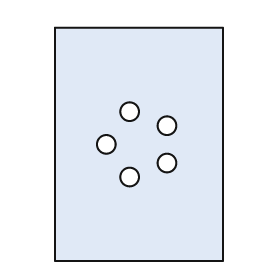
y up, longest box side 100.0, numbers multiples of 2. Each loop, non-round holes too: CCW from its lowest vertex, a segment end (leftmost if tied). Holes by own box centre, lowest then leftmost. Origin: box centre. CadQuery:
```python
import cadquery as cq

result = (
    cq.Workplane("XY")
    .moveTo(-36.0, -50.0)
    .lineTo(36.0, -50.0)
    .lineTo(36.0, 50.0)
    .lineTo(-36.0, 50.0)
    .close()
    .moveTo(-4.0, -14.0)
    .circle(4.0)
    .moveTo(12.0, -8.0)
    .circle(4.0)
    .moveTo(-14.0, 0.0)
    .circle(4.0)
    .moveTo(12.0, 8.0)
    .circle(4.0)
    .moveTo(-4.0, 14.0)
    .circle(4.0)
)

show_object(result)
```